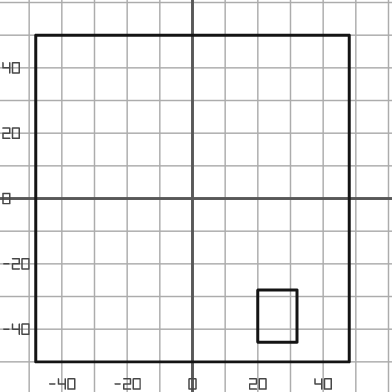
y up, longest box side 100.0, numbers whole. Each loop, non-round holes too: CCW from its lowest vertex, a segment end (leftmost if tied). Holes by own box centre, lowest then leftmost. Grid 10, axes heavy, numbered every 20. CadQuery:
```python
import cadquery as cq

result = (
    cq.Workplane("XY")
    .moveTo(-48.0, -50.0)
    .lineTo(48.0, -50.0)
    .lineTo(48.0, 50.0)
    .lineTo(-48.0, 50.0)
    .close()
    .moveTo(20.0, -44.0)
    .lineTo(32.0, -44.0)
    .lineTo(32.0, -28.0)
    .lineTo(20.0, -28.0)
    .close()
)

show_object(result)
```